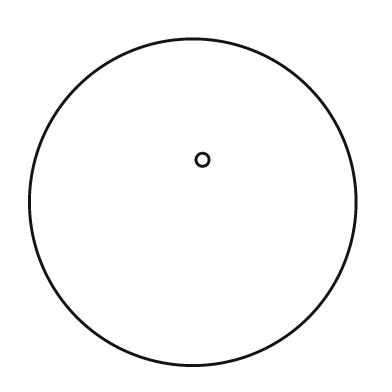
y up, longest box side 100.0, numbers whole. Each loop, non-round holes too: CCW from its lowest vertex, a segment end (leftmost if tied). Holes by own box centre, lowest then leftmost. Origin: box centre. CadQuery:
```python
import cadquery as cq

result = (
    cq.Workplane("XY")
    .moveTo(0.0, 0.0)
    .circle(50.0)
    .moveTo(3.0, 13.0)
    .circle(2.0)
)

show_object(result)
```